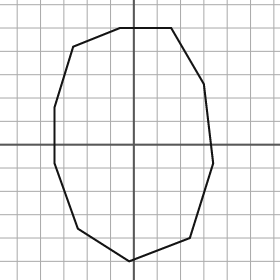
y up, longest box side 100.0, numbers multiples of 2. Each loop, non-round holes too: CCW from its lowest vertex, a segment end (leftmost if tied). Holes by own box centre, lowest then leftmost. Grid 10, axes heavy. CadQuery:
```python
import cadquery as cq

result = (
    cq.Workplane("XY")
    .moveTo(-2.0, -50.0)
    .lineTo(24.0, -40.0)
    .lineTo(34.0, -8.0)
    .lineTo(30.0, 26.0)
    .lineTo(16.0, 50.0)
    .lineTo(-6.0, 50.0)
    .lineTo(-26.0, 42.0)
    .lineTo(-34.0, 16.0)
    .lineTo(-34.0, -8.0)
    .lineTo(-24.0, -36.0)
    .close()
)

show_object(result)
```